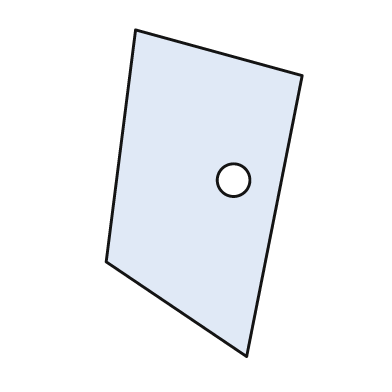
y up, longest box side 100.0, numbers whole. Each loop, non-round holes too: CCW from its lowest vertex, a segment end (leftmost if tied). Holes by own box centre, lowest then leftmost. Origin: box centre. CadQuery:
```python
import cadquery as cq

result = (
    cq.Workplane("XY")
    .moveTo(13.0, -50.0)
    .lineTo(30.0, 36.0)
    .lineTo(-21.0, 50.0)
    .lineTo(-30.0, -21.0)
    .close()
    .moveTo(9.0, 4.0)
    .circle(5.0)
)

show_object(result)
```